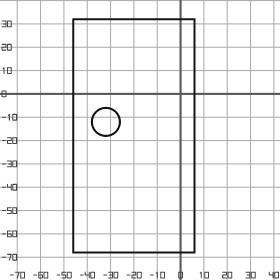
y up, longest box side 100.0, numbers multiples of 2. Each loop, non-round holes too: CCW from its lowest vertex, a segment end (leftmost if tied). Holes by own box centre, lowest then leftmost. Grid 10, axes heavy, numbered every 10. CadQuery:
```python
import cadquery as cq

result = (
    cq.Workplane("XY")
    .moveTo(-46.0, -68.0)
    .lineTo(6.0, -68.0)
    .lineTo(6.0, 32.0)
    .lineTo(-46.0, 32.0)
    .close()
    .moveTo(-32.0, -12.0)
    .circle(6.0)
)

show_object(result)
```